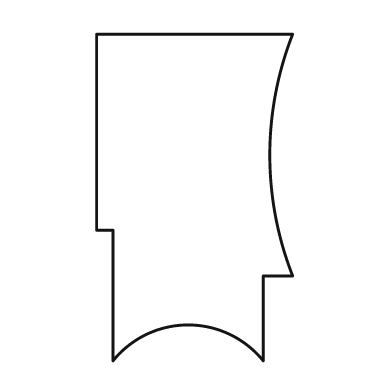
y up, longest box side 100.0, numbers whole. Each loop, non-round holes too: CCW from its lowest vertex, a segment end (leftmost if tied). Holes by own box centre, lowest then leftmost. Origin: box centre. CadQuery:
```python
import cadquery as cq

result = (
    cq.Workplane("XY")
    .moveTo(-25.0, -50.0)
    .threePointArc((-2.0, -39.0), (21.0, -50.0))
    .lineTo(21.0, -24.0)
    .lineTo(30.0, -24.0)
    .threePointArc((23.0, 13.0), (30.0, 50.0))
    .lineTo(-30.0, 50.0)
    .lineTo(-30.0, -10.0)
    .lineTo(-25.0, -10.0)
    .close()
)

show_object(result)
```